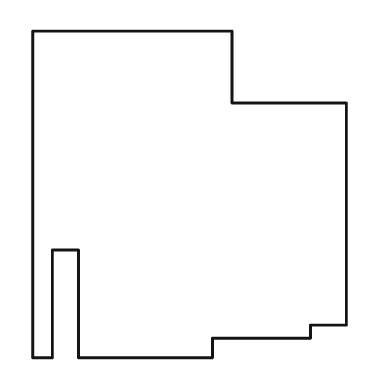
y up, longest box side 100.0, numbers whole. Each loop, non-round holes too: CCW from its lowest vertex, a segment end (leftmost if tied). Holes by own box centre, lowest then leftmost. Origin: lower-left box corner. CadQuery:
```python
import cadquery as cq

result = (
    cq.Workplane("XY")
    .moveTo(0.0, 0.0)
    .lineTo(6.0, 0.0)
    .lineTo(6.0, 33.0)
    .lineTo(14.0, 33.0)
    .lineTo(14.0, 0.0)
    .lineTo(55.0, 0.0)
    .lineTo(55.0, 6.0)
    .lineTo(85.0, 6.0)
    .lineTo(85.0, 10.0)
    .lineTo(96.0, 10.0)
    .lineTo(96.0, 78.0)
    .lineTo(61.0, 78.0)
    .lineTo(61.0, 100.0)
    .lineTo(0.0, 100.0)
    .close()
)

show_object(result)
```